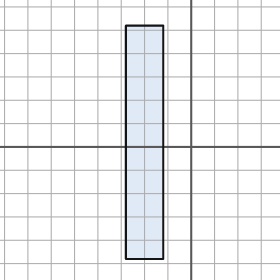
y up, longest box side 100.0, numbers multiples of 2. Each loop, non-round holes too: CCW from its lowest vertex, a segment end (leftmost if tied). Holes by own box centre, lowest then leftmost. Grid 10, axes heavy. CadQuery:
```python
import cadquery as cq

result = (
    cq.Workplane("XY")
    .moveTo(-28.0, -48.0)
    .lineTo(-12.0, -48.0)
    .lineTo(-12.0, 52.0)
    .lineTo(-28.0, 52.0)
    .close()
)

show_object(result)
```